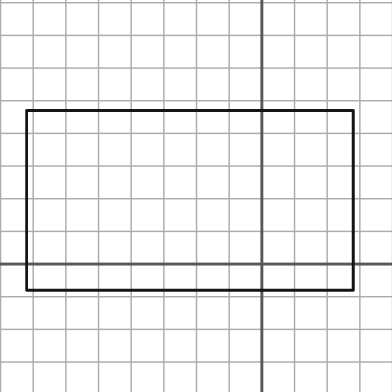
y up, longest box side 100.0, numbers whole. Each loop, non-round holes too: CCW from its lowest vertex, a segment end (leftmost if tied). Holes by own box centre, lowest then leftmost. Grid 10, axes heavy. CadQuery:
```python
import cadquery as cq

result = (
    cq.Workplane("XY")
    .moveTo(-72.0, -8.0)
    .lineTo(28.0, -8.0)
    .lineTo(28.0, 47.0)
    .lineTo(-72.0, 47.0)
    .close()
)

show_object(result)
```